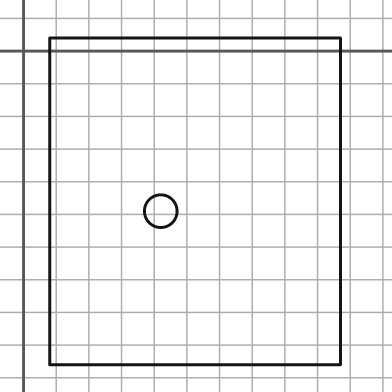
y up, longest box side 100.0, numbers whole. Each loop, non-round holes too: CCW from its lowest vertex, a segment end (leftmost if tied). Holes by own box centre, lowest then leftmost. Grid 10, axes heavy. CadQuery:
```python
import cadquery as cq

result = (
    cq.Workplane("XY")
    .moveTo(8.0, -96.0)
    .lineTo(97.0, -96.0)
    .lineTo(97.0, 4.0)
    .lineTo(8.0, 4.0)
    .close()
    .moveTo(42.0, -49.0)
    .circle(5.0)
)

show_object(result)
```